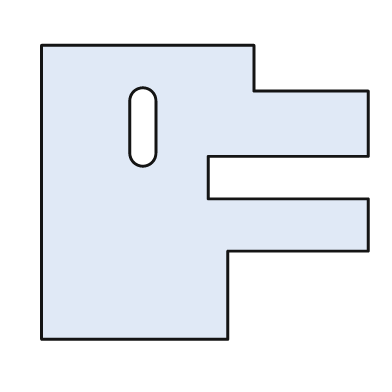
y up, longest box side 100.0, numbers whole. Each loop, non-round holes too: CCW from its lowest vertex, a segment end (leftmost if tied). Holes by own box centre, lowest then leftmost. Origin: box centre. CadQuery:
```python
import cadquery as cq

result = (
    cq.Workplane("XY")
    .moveTo(-50.0, -45.0)
    .lineTo(7.0, -45.0)
    .lineTo(7.0, -18.0)
    .lineTo(50.0, -18.0)
    .lineTo(50.0, -2.0)
    .lineTo(1.0, -2.0)
    .lineTo(1.0, 11.0)
    .lineTo(50.0, 11.0)
    .lineTo(50.0, 31.0)
    .lineTo(15.0, 31.0)
    .lineTo(15.0, 45.0)
    .lineTo(-50.0, 45.0)
    .close()
    .moveTo(-23.0, 12.0)
    .threePointArc((-19.0, 8.0), (-15.0, 12.0))
    .lineTo(-15.0, 28.0)
    .threePointArc((-19.0, 32.0), (-23.0, 28.0))
    .close()
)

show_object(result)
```